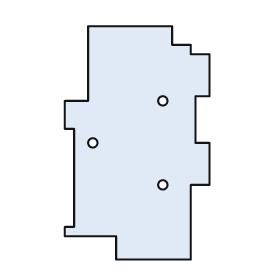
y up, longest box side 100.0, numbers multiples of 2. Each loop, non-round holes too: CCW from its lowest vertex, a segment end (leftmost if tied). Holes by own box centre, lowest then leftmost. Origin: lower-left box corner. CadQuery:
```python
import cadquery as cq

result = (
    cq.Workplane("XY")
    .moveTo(22.0, 0.0)
    .lineTo(54.0, 0.0)
    .lineTo(54.0, 32.0)
    .lineTo(62.0, 32.0)
    .lineTo(62.0, 50.0)
    .lineTo(56.0, 50.0)
    .lineTo(56.0, 70.0)
    .lineTo(62.0, 70.0)
    .lineTo(62.0, 88.0)
    .lineTo(54.0, 88.0)
    .lineTo(54.0, 92.0)
    .lineTo(46.0, 92.0)
    .lineTo(46.0, 100.0)
    .lineTo(10.0, 100.0)
    .lineTo(10.0, 68.0)
    .lineTo(0.0, 68.0)
    .lineTo(0.0, 56.0)
    .lineTo(4.0, 56.0)
    .lineTo(4.0, 14.0)
    .lineTo(0.0, 14.0)
    .lineTo(0.0, 10.0)
    .lineTo(22.0, 10.0)
    .close()
    .moveTo(42.0, 32.0)
    .circle(2.0)
    .moveTo(12.0, 50.0)
    .circle(2.0)
    .moveTo(42.0, 68.0)
    .circle(2.0)
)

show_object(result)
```